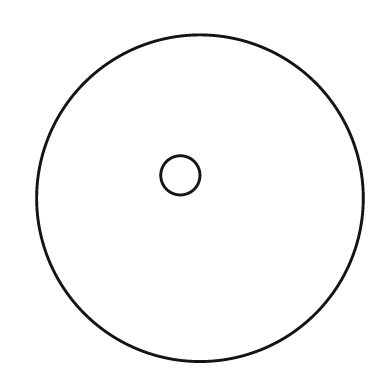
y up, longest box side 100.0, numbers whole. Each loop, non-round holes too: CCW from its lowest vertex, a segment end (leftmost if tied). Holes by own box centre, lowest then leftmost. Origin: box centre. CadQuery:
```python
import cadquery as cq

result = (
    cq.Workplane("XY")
    .moveTo(0.0, 0.0)
    .circle(50.0)
    .moveTo(-6.0, 7.0)
    .circle(6.0)
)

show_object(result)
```